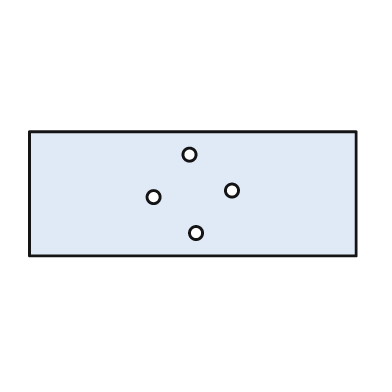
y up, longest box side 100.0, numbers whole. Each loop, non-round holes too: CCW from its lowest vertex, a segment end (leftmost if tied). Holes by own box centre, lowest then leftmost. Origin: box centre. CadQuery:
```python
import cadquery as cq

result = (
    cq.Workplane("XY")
    .moveTo(-50.0, -19.0)
    .lineTo(50.0, -19.0)
    .lineTo(50.0, 19.0)
    .lineTo(-50.0, 19.0)
    .close()
    .moveTo(1.0, -12.0)
    .circle(2.0)
    .moveTo(-12.0, -1.0)
    .circle(2.0)
    .moveTo(12.0, 1.0)
    .circle(2.0)
    .moveTo(-1.0, 12.0)
    .circle(2.0)
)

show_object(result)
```